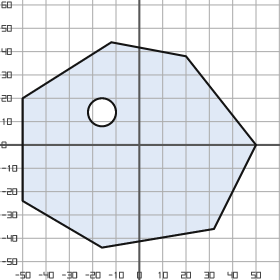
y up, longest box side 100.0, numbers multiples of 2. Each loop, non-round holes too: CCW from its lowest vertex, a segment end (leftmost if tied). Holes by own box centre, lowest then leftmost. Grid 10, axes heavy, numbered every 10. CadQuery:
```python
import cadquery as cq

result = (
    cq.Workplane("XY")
    .moveTo(-16.0, -44.0)
    .lineTo(32.0, -36.0)
    .lineTo(50.0, 0.0)
    .lineTo(20.0, 38.0)
    .lineTo(-12.0, 44.0)
    .lineTo(-50.0, 20.0)
    .lineTo(-50.0, -24.0)
    .close()
    .moveTo(-16.0, 14.0)
    .circle(6.0)
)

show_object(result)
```